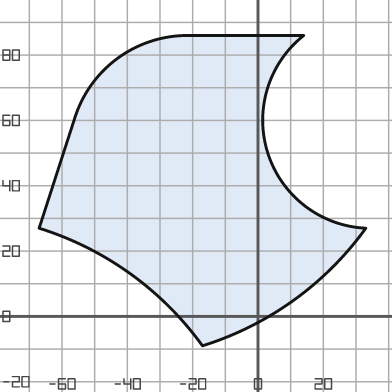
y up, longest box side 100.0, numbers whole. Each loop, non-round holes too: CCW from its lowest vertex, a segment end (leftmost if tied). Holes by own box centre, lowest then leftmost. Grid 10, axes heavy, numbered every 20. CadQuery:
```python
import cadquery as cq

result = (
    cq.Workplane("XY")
    .moveTo(-17.0, -9.0)
    .threePointArc((11.0, 5.0), (33.0, 27.0))
    .threePointArc((3.0, 50.0), (14.0, 86.0))
    .lineTo(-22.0, 86.0)
    .threePointArc((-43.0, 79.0), (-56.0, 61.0))
    .lineTo(-67.0, 27.0)
    .threePointArc((-39.0, 13.0), (-17.0, -9.0))
    .close()
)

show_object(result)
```